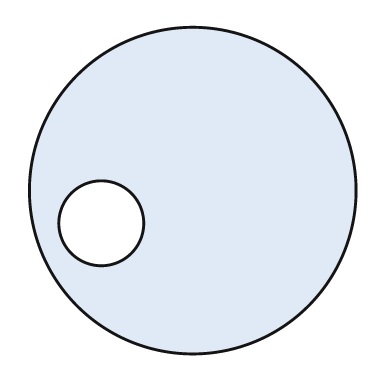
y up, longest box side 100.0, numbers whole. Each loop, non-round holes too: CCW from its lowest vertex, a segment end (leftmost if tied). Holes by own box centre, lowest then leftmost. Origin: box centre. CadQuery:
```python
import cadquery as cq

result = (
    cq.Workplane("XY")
    .moveTo(0.0, 0.0)
    .circle(50.0)
    .moveTo(-28.0, -10.0)
    .circle(13.0)
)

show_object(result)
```